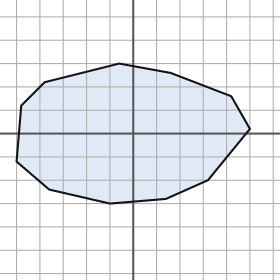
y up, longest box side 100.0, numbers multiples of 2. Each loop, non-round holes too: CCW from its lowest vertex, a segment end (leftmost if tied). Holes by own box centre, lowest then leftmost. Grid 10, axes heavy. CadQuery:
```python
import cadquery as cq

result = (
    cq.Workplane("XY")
    .moveTo(-10.0, -30.0)
    .lineTo(14.0, -28.0)
    .lineTo(32.0, -20.0)
    .lineTo(50.0, 2.0)
    .lineTo(42.0, 16.0)
    .lineTo(16.0, 26.0)
    .lineTo(-6.0, 30.0)
    .lineTo(-38.0, 22.0)
    .lineTo(-48.0, 12.0)
    .lineTo(-50.0, -12.0)
    .lineTo(-36.0, -24.0)
    .close()
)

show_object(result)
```